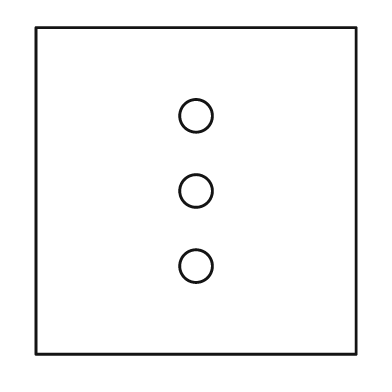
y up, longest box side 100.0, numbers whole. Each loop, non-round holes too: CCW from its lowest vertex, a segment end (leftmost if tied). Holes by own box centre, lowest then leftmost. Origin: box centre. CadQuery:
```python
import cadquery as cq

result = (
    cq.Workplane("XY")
    .moveTo(-49.0, -50.0)
    .lineTo(49.0, -50.0)
    .lineTo(49.0, 50.0)
    .lineTo(-49.0, 50.0)
    .close()
    .moveTo(0.0, -23.0)
    .circle(5.0)
    .moveTo(0.0, 0.0)
    .circle(5.0)
    .moveTo(0.0, 23.0)
    .circle(5.0)
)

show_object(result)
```